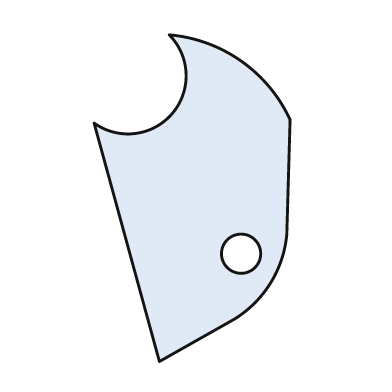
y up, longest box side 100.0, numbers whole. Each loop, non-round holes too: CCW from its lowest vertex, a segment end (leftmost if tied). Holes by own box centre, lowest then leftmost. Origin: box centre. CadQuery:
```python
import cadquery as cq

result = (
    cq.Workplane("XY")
    .moveTo(-10.0, -50.0)
    .lineTo(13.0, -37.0)
    .threePointArc((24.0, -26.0), (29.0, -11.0))
    .lineTo(30.0, 24.0)
    .threePointArc((15.0, 42.0), (-7.0, 50.0))
    .threePointArc((-6.0, 26.0), (-30.0, 23.0))
    .close()
    .moveTo(15.0, -17.0)
    .circle(6.0)
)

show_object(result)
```